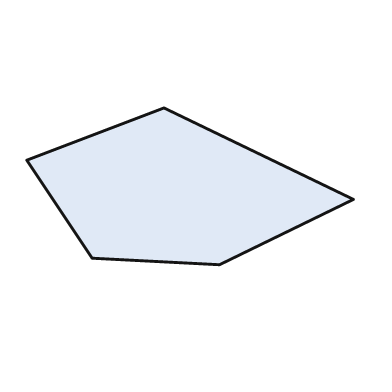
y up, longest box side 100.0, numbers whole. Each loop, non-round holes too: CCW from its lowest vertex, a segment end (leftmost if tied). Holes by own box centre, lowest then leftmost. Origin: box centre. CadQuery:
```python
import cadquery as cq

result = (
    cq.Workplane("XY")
    .moveTo(9.0, -24.0)
    .lineTo(50.0, -4.0)
    .lineTo(-8.0, 24.0)
    .lineTo(-50.0, 8.0)
    .lineTo(-30.0, -22.0)
    .close()
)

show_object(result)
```